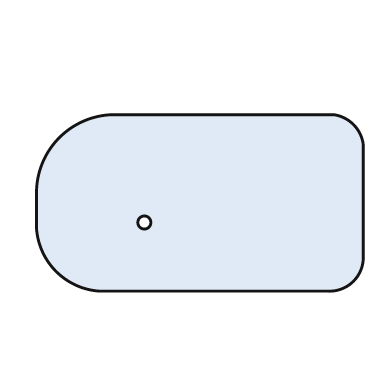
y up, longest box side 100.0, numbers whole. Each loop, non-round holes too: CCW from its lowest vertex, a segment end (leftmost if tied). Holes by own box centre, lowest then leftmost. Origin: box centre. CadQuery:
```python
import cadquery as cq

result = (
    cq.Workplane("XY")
    .moveTo(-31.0, -27.0)
    .lineTo(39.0, -27.0)
    .threePointArc((47.0, -24.0), (50.0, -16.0))
    .lineTo(50.0, 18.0)
    .threePointArc((47.0, 24.0), (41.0, 27.0))
    .lineTo(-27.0, 27.0)
    .threePointArc((-43.0, 20.0), (-50.0, 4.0))
    .lineTo(-50.0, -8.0)
    .threePointArc((-44.0, -21.0), (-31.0, -27.0))
    .close()
    .moveTo(-17.0, -6.0)
    .circle(2.0)
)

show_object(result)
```